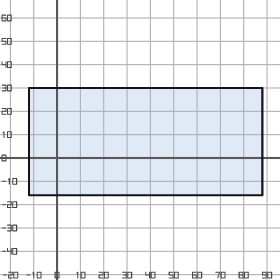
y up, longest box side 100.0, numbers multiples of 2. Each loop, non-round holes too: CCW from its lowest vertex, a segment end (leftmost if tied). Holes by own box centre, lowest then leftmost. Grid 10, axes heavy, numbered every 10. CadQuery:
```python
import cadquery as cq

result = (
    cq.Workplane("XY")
    .moveTo(-12.0, -16.0)
    .lineTo(88.0, -16.0)
    .lineTo(88.0, 30.0)
    .lineTo(-12.0, 30.0)
    .close()
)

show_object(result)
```